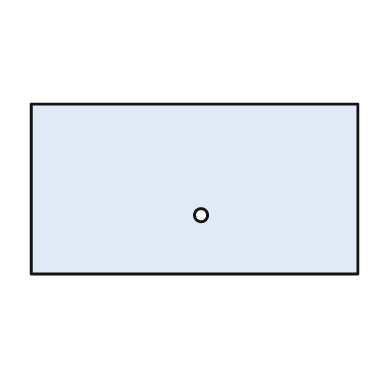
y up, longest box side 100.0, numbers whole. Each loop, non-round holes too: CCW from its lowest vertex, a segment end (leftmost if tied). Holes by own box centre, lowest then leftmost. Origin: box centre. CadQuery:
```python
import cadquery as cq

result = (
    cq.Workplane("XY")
    .moveTo(-50.0, -26.0)
    .lineTo(50.0, -26.0)
    .lineTo(50.0, 26.0)
    .lineTo(-50.0, 26.0)
    .close()
    .moveTo(2.0, -8.0)
    .circle(2.0)
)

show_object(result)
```